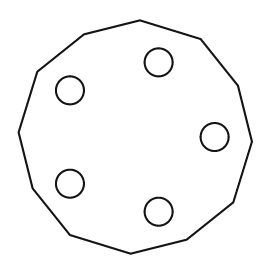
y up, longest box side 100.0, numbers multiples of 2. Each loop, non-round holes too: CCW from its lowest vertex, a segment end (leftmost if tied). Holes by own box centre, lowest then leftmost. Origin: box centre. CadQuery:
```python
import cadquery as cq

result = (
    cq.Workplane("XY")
    .moveTo(-2.0, -50.0)
    .lineTo(22.0, -44.0)
    .lineTo(42.0, -28.0)
    .lineTo(50.0, -2.0)
    .lineTo(44.0, 22.0)
    .lineTo(28.0, 42.0)
    .lineTo(2.0, 50.0)
    .lineTo(-22.0, 44.0)
    .lineTo(-42.0, 28.0)
    .lineTo(-50.0, 2.0)
    .lineTo(-44.0, -22.0)
    .lineTo(-28.0, -42.0)
    .close()
    .moveTo(10.0, -32.0)
    .circle(6.0)
    .moveTo(-28.0, -20.0)
    .circle(6.0)
    .moveTo(34.0, 0.0)
    .circle(6.0)
    .moveTo(-28.0, 20.0)
    .circle(6.0)
    .moveTo(10.0, 32.0)
    .circle(6.0)
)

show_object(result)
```